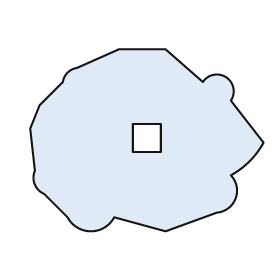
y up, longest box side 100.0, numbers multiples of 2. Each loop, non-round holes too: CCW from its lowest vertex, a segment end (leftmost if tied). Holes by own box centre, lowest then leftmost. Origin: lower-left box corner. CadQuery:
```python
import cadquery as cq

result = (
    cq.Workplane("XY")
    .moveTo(58.0, 0.0)
    .lineTo(80.0, 8.0)
    .threePointArc((88.0, 14.0), (86.0, 24.0))
    .threePointArc((94.0, 30.0), (100.0, 38.0))
    .lineTo(86.0, 56.0)
    .threePointArc((84.0, 66.0), (74.0, 64.0))
    .lineTo(58.0, 78.0)
    .lineTo(38.0, 78.0)
    .lineTo(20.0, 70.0)
    .threePointArc((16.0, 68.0), (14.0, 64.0))
    .lineTo(4.0, 54.0)
    .lineTo(0.0, 44.0)
    .lineTo(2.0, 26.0)
    .threePointArc((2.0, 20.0), (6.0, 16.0))
    .lineTo(16.0, 6.0)
    .threePointArc((26.0, 0.0), (36.0, 6.0))
    .close()
    .moveTo(44.0, 34.0)
    .lineTo(56.0, 34.0)
    .lineTo(56.0, 46.0)
    .lineTo(44.0, 46.0)
    .close()
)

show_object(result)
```